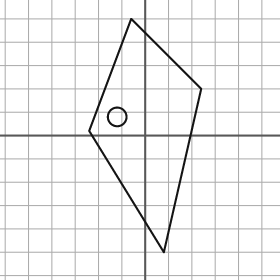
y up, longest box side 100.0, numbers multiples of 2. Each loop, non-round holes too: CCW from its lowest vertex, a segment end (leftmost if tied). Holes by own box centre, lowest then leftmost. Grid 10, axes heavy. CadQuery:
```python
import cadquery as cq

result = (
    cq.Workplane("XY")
    .moveTo(8.0, -50.0)
    .lineTo(24.0, 20.0)
    .lineTo(-6.0, 50.0)
    .lineTo(-24.0, 2.0)
    .close()
    .moveTo(-12.0, 8.0)
    .circle(4.0)
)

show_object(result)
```